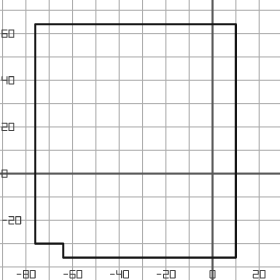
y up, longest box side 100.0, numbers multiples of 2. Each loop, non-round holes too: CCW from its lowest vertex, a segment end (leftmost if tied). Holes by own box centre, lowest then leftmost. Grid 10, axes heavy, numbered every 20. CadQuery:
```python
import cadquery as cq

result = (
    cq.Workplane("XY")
    .moveTo(-64.0, -36.0)
    .lineTo(10.0, -36.0)
    .lineTo(10.0, 64.0)
    .lineTo(-76.0, 64.0)
    .lineTo(-76.0, -30.0)
    .lineTo(-64.0, -30.0)
    .close()
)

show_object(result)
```